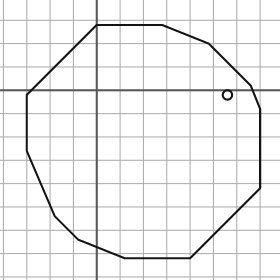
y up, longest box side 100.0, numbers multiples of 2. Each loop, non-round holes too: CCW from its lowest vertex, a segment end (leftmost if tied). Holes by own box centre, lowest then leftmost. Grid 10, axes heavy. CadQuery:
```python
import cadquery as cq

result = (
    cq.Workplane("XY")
    .moveTo(12.0, -72.0)
    .lineTo(40.0, -72.0)
    .lineTo(70.0, -42.0)
    .lineTo(70.0, -8.0)
    .lineTo(66.0, 2.0)
    .lineTo(48.0, 20.0)
    .lineTo(28.0, 28.0)
    .lineTo(0.0, 28.0)
    .lineTo(-30.0, -2.0)
    .lineTo(-30.0, -26.0)
    .lineTo(-18.0, -54.0)
    .lineTo(-8.0, -64.0)
    .close()
    .moveTo(56.0, -2.0)
    .circle(2.0)
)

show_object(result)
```